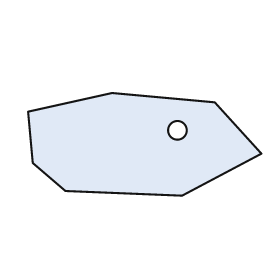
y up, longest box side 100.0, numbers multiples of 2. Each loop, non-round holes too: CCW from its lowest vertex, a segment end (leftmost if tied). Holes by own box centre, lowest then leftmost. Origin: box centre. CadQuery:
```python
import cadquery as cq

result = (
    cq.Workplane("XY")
    .moveTo(16.0, -22.0)
    .lineTo(50.0, -4.0)
    .lineTo(30.0, 18.0)
    .lineTo(-14.0, 22.0)
    .lineTo(-50.0, 14.0)
    .lineTo(-48.0, -8.0)
    .lineTo(-34.0, -20.0)
    .close()
    .moveTo(14.0, 6.0)
    .circle(4.0)
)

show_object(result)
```